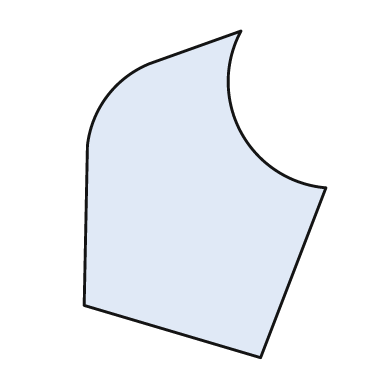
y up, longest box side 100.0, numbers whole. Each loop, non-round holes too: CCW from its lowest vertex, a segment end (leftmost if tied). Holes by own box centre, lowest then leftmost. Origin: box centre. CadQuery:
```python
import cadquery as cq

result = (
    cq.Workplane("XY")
    .moveTo(17.0, -50.0)
    .lineTo(37.0, 2.0)
    .threePointArc((11.0, 19.0), (11.0, 50.0))
    .lineTo(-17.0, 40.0)
    .threePointArc((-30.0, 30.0), (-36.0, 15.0))
    .lineTo(-37.0, -34.0)
    .close()
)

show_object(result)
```